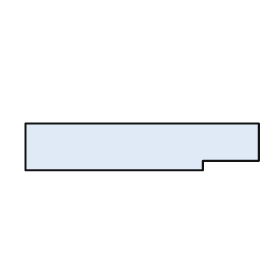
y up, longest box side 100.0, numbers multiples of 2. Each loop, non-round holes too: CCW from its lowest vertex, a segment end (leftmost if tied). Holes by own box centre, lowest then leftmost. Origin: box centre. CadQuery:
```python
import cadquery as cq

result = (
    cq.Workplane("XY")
    .moveTo(-50.0, -10.0)
    .lineTo(26.0, -10.0)
    .lineTo(26.0, -6.0)
    .lineTo(50.0, -6.0)
    .lineTo(50.0, 10.0)
    .lineTo(-50.0, 10.0)
    .close()
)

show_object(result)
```